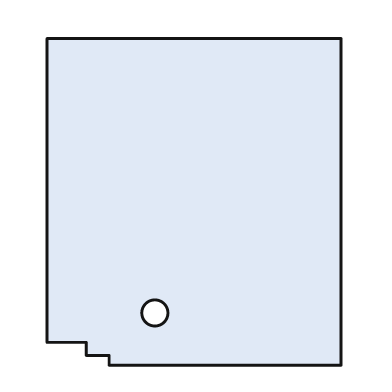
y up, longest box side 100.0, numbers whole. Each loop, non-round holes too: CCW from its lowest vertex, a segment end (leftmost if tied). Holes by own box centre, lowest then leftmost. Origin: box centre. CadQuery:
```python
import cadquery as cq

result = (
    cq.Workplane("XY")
    .moveTo(-26.0, -50.0)
    .lineTo(45.0, -50.0)
    .lineTo(45.0, 50.0)
    .lineTo(-45.0, 50.0)
    .lineTo(-45.0, -43.0)
    .lineTo(-33.0, -43.0)
    .lineTo(-33.0, -47.0)
    .lineTo(-26.0, -47.0)
    .close()
    .moveTo(-12.0, -34.0)
    .circle(4.0)
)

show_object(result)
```